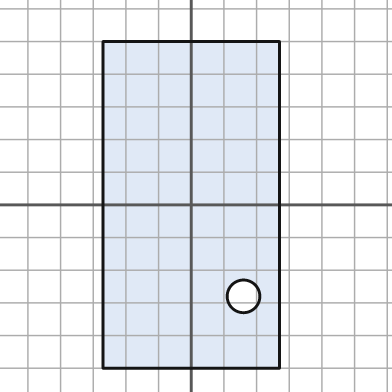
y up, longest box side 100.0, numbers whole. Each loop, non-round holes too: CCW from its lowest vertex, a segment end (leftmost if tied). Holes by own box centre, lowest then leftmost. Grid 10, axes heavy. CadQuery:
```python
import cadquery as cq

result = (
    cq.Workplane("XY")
    .moveTo(-27.0, -50.0)
    .lineTo(27.0, -50.0)
    .lineTo(27.0, 50.0)
    .lineTo(-27.0, 50.0)
    .close()
    .moveTo(16.0, -28.0)
    .circle(5.0)
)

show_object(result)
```